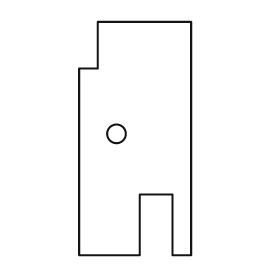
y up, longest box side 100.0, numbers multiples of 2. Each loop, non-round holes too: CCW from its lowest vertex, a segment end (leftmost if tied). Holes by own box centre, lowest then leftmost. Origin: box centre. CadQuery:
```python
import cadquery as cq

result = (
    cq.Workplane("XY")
    .moveTo(-24.0, -50.0)
    .lineTo(2.0, -50.0)
    .lineTo(2.0, -24.0)
    .lineTo(16.0, -24.0)
    .lineTo(16.0, -50.0)
    .lineTo(24.0, -50.0)
    .lineTo(24.0, 50.0)
    .lineTo(-16.0, 50.0)
    .lineTo(-16.0, 30.0)
    .lineTo(-24.0, 30.0)
    .close()
    .moveTo(-8.0, 2.0)
    .circle(4.0)
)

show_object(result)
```